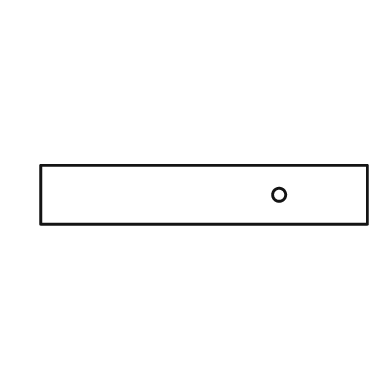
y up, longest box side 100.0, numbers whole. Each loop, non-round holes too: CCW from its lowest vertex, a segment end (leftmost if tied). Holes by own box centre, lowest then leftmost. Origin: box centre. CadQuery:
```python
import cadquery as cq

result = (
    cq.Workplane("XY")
    .moveTo(-50.0, -9.0)
    .lineTo(50.0, -9.0)
    .lineTo(50.0, 9.0)
    .lineTo(-50.0, 9.0)
    .close()
    .moveTo(23.0, 0.0)
    .circle(2.0)
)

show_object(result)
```